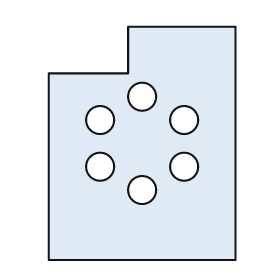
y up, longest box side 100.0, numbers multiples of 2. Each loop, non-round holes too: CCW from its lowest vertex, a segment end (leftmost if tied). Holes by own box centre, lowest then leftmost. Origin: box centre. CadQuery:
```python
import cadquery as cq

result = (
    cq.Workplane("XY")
    .moveTo(-40.0, -50.0)
    .lineTo(40.0, -50.0)
    .lineTo(40.0, 50.0)
    .lineTo(-6.0, 50.0)
    .lineTo(-6.0, 30.0)
    .lineTo(-40.0, 30.0)
    .close()
    .moveTo(0.0, -20.0)
    .circle(6.0)
    .moveTo(-18.0, -10.0)
    .circle(6.0)
    .moveTo(18.0, -10.0)
    .circle(6.0)
    .moveTo(-18.0, 10.0)
    .circle(6.0)
    .moveTo(18.0, 10.0)
    .circle(6.0)
    .moveTo(0.0, 20.0)
    .circle(6.0)
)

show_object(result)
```